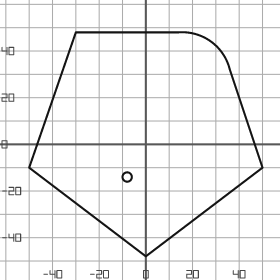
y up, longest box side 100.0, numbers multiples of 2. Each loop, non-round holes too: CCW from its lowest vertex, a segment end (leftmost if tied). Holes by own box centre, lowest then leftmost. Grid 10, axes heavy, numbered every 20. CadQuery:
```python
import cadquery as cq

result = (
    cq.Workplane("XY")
    .moveTo(0.0, -48.0)
    .lineTo(50.0, -10.0)
    .lineTo(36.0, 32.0)
    .threePointArc((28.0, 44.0), (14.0, 48.0))
    .lineTo(-30.0, 48.0)
    .lineTo(-50.0, -10.0)
    .close()
    .moveTo(-8.0, -14.0)
    .circle(2.0)
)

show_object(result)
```